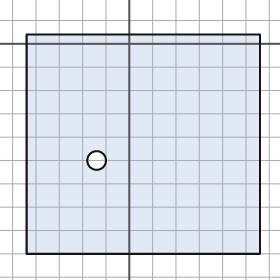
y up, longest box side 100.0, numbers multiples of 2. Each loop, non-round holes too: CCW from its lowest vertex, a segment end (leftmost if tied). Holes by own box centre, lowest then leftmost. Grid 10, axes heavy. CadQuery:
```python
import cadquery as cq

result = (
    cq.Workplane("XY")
    .moveTo(-44.0, -90.0)
    .lineTo(56.0, -90.0)
    .lineTo(56.0, 4.0)
    .lineTo(-44.0, 4.0)
    .close()
    .moveTo(-14.0, -50.0)
    .circle(4.0)
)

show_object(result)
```